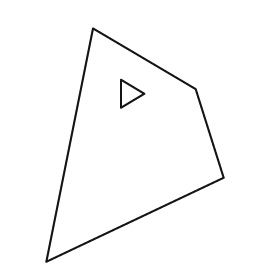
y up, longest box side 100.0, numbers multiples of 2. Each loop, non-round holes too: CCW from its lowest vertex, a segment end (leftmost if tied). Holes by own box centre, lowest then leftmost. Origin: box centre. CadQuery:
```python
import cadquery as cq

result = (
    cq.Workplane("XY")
    .moveTo(-38.0, -50.0)
    .lineTo(38.0, -14.0)
    .lineTo(26.0, 24.0)
    .lineTo(-18.0, 50.0)
    .close()
    .moveTo(-6.0, 16.0)
    .lineTo(4.0, 22.0)
    .lineTo(-6.0, 28.0)
    .close()
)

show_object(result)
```